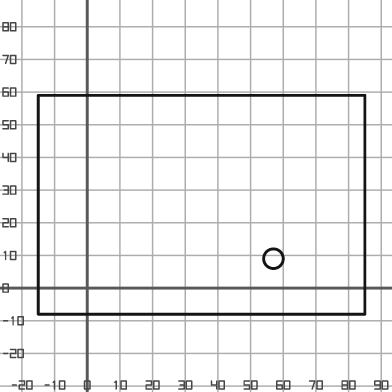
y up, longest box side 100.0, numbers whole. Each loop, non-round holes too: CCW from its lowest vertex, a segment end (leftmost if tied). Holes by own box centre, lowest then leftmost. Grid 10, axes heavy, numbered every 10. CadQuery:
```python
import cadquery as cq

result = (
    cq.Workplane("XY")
    .moveTo(-15.0, -8.0)
    .lineTo(85.0, -8.0)
    .lineTo(85.0, 59.0)
    .lineTo(-15.0, 59.0)
    .close()
    .moveTo(57.0, 9.0)
    .circle(3.0)
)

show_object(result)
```